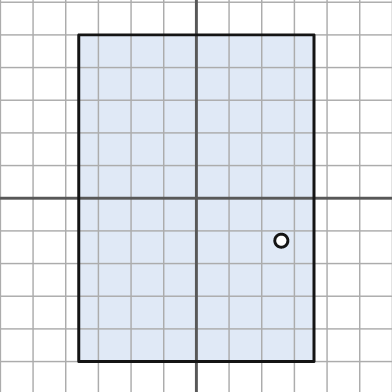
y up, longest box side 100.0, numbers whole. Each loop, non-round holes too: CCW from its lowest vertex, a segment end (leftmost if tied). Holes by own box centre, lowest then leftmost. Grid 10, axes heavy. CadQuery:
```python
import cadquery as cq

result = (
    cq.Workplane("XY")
    .moveTo(-36.0, -50.0)
    .lineTo(36.0, -50.0)
    .lineTo(36.0, 50.0)
    .lineTo(-36.0, 50.0)
    .close()
    .moveTo(26.0, -13.0)
    .circle(2.0)
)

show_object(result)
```